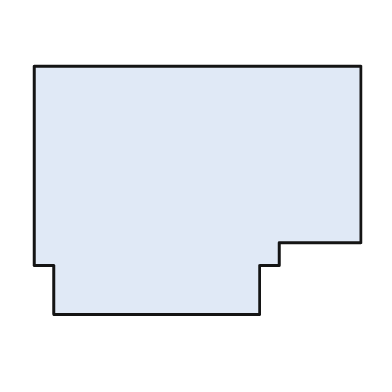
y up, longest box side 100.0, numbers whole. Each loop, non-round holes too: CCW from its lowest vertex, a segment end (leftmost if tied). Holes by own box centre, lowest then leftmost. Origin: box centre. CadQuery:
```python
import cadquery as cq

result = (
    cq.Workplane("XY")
    .moveTo(-44.0, -38.0)
    .lineTo(19.0, -38.0)
    .lineTo(19.0, -23.0)
    .lineTo(25.0, -23.0)
    .lineTo(25.0, -16.0)
    .lineTo(50.0, -16.0)
    .lineTo(50.0, 38.0)
    .lineTo(-50.0, 38.0)
    .lineTo(-50.0, -23.0)
    .lineTo(-44.0, -23.0)
    .close()
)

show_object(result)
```